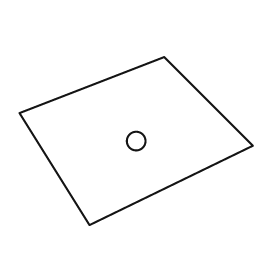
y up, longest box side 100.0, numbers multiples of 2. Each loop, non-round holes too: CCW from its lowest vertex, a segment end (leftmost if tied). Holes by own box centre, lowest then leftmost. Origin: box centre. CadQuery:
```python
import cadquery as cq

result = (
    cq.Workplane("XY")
    .moveTo(-20.0, -36.0)
    .lineTo(50.0, -2.0)
    .lineTo(12.0, 36.0)
    .lineTo(-50.0, 12.0)
    .close()
    .moveTo(0.0, 0.0)
    .circle(4.0)
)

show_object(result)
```